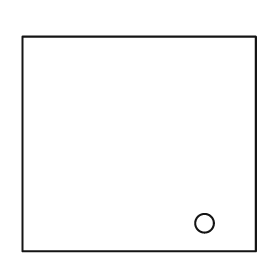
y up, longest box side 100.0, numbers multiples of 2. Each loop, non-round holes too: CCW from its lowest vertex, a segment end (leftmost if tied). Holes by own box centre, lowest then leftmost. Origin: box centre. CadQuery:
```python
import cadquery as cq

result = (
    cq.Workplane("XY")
    .moveTo(-50.0, -46.0)
    .lineTo(50.0, -46.0)
    .lineTo(50.0, 46.0)
    .lineTo(-50.0, 46.0)
    .close()
    .moveTo(28.0, -34.0)
    .circle(4.0)
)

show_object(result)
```